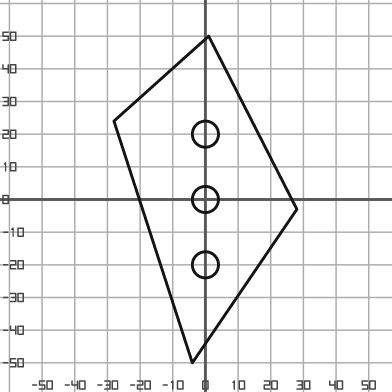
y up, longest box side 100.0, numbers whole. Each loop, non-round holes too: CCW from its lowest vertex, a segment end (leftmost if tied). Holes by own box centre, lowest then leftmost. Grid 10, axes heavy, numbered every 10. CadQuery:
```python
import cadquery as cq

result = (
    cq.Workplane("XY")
    .moveTo(-4.0, -50.0)
    .lineTo(28.0, -3.0)
    .lineTo(1.0, 50.0)
    .lineTo(-28.0, 24.0)
    .close()
    .moveTo(0.0, -20.0)
    .circle(4.0)
    .moveTo(0.0, 0.0)
    .circle(4.0)
    .moveTo(0.0, 20.0)
    .circle(4.0)
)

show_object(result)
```